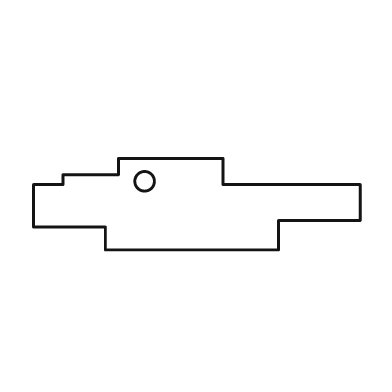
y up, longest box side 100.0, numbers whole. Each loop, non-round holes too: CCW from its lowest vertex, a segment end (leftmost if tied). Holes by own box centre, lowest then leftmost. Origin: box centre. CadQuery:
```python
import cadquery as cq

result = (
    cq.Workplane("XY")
    .moveTo(-28.0, -14.0)
    .lineTo(25.0, -14.0)
    .lineTo(25.0, -5.0)
    .lineTo(50.0, -5.0)
    .lineTo(50.0, 6.0)
    .lineTo(8.0, 6.0)
    .lineTo(8.0, 14.0)
    .lineTo(-24.0, 14.0)
    .lineTo(-24.0, 9.0)
    .lineTo(-41.0, 9.0)
    .lineTo(-41.0, 6.0)
    .lineTo(-50.0, 6.0)
    .lineTo(-50.0, -7.0)
    .lineTo(-28.0, -7.0)
    .close()
    .moveTo(-16.0, 7.0)
    .circle(3.0)
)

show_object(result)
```